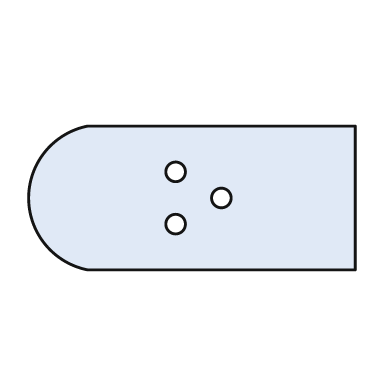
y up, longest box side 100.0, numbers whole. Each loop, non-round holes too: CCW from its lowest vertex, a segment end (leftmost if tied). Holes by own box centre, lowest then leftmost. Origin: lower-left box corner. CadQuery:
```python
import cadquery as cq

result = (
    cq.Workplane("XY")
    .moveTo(18.0, 0.0)
    .lineTo(100.0, 0.0)
    .lineTo(100.0, 44.0)
    .lineTo(18.0, 44.0)
    .threePointArc((0.0, 22.0), (18.0, 0.0))
    .close()
    .moveTo(45.0, 14.0)
    .circle(3.0)
    .moveTo(59.0, 22.0)
    .circle(3.0)
    .moveTo(45.0, 30.0)
    .circle(3.0)
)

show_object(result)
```